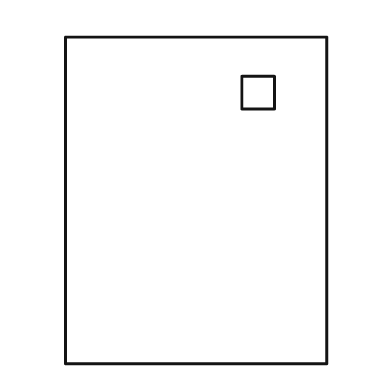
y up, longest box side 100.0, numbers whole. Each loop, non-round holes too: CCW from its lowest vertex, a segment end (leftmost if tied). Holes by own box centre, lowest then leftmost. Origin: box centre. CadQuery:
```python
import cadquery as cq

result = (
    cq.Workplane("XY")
    .moveTo(-40.0, -50.0)
    .lineTo(40.0, -50.0)
    .lineTo(40.0, 50.0)
    .lineTo(-40.0, 50.0)
    .close()
    .moveTo(14.0, 28.0)
    .lineTo(24.0, 28.0)
    .lineTo(24.0, 38.0)
    .lineTo(14.0, 38.0)
    .close()
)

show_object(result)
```